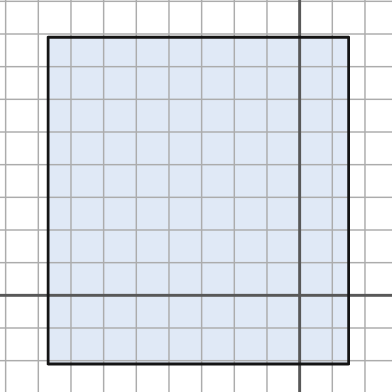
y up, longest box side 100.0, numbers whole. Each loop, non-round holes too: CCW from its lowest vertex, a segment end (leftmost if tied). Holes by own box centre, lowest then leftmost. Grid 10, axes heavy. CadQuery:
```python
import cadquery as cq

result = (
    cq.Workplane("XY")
    .moveTo(-77.0, -21.0)
    .lineTo(15.0, -21.0)
    .lineTo(15.0, 79.0)
    .lineTo(-77.0, 79.0)
    .close()
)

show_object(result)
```